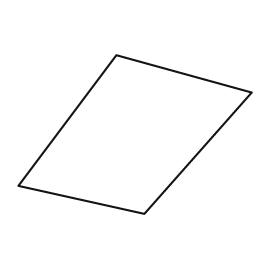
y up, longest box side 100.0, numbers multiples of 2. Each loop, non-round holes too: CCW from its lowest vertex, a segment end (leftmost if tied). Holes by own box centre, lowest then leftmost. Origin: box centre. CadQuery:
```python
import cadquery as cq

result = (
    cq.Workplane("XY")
    .moveTo(4.0, -34.0)
    .lineTo(50.0, 18.0)
    .lineTo(-8.0, 34.0)
    .lineTo(-50.0, -22.0)
    .close()
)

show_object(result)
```